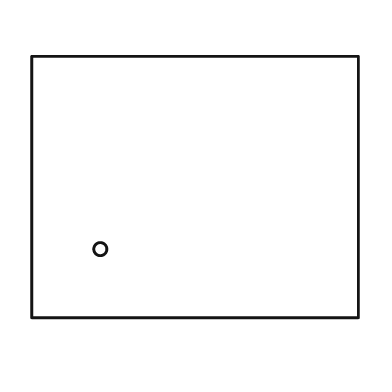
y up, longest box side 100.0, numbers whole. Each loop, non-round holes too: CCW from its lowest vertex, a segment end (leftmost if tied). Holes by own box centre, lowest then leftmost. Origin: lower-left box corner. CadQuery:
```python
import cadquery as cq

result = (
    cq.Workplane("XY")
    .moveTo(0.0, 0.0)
    .lineTo(100.0, 0.0)
    .lineTo(100.0, 80.0)
    .lineTo(0.0, 80.0)
    .close()
    .moveTo(21.0, 21.0)
    .circle(2.0)
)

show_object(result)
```